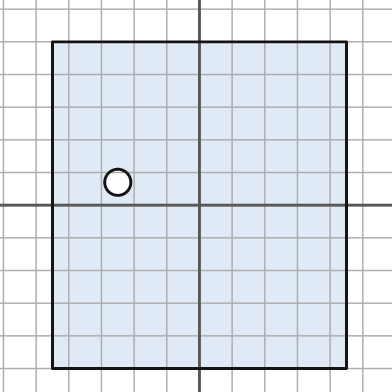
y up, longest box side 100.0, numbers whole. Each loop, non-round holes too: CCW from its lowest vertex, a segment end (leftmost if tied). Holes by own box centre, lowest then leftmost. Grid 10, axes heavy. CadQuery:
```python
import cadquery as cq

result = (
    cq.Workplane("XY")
    .moveTo(-45.0, -50.0)
    .lineTo(45.0, -50.0)
    .lineTo(45.0, 50.0)
    .lineTo(-45.0, 50.0)
    .close()
    .moveTo(-25.0, 7.0)
    .circle(4.0)
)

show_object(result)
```